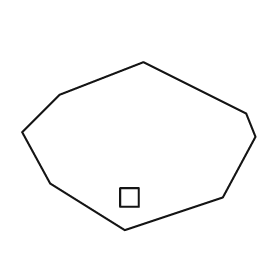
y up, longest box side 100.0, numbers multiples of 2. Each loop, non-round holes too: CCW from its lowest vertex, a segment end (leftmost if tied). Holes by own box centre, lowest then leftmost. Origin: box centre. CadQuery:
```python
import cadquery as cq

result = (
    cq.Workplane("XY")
    .moveTo(-6.0, -36.0)
    .lineTo(36.0, -22.0)
    .lineTo(50.0, 4.0)
    .lineTo(46.0, 14.0)
    .lineTo(2.0, 36.0)
    .lineTo(-34.0, 22.0)
    .lineTo(-50.0, 6.0)
    .lineTo(-38.0, -16.0)
    .close()
    .moveTo(-8.0, -26.0)
    .lineTo(0.0, -26.0)
    .lineTo(0.0, -18.0)
    .lineTo(-8.0, -18.0)
    .close()
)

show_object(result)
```